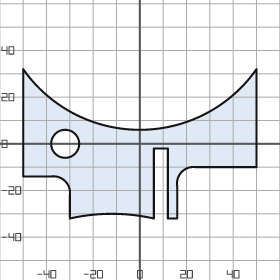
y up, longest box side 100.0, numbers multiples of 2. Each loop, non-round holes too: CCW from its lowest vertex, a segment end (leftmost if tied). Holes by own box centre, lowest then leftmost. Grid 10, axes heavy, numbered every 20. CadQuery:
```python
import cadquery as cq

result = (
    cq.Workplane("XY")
    .moveTo(-30.0, -32.0)
    .threePointArc((-12.0, -30.0), (6.0, -32.0))
    .lineTo(6.0, -2.0)
    .lineTo(12.0, -2.0)
    .lineTo(12.0, -32.0)
    .lineTo(16.0, -32.0)
    .lineTo(16.0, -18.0)
    .threePointArc((18.0, -12.0), (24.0, -10.0))
    .lineTo(50.0, -10.0)
    .lineTo(50.0, 32.0)
    .threePointArc((0.0, 6.0), (-50.0, 32.0))
    .lineTo(-50.0, -14.0)
    .lineTo(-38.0, -14.0)
    .threePointArc((-32.0, -16.0), (-30.0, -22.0))
    .close()
    .moveTo(-32.0, 0.0)
    .circle(6.0)
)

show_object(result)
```